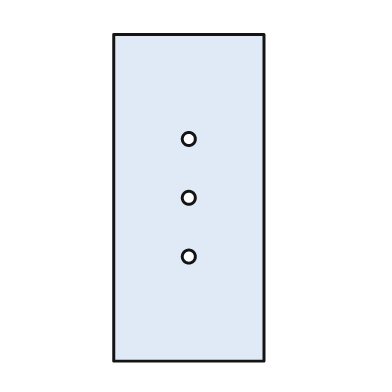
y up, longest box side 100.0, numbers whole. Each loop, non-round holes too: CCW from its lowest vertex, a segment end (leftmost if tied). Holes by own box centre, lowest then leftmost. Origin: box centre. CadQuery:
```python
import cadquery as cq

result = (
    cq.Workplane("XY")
    .moveTo(-23.0, -50.0)
    .lineTo(23.0, -50.0)
    .lineTo(23.0, 50.0)
    .lineTo(-23.0, 50.0)
    .close()
    .moveTo(0.0, -18.0)
    .circle(2.0)
    .moveTo(0.0, 0.0)
    .circle(2.0)
    .moveTo(0.0, 18.0)
    .circle(2.0)
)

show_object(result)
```